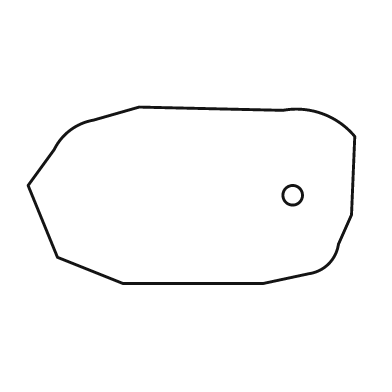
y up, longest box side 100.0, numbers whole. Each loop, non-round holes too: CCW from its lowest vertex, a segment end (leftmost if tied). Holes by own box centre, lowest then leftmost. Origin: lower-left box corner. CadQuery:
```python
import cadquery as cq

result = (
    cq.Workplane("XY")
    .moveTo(29.0, 0.0)
    .lineTo(72.0, 0.0)
    .lineTo(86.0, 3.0)
    .threePointArc((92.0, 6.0), (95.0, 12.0))
    .lineTo(99.0, 21.0)
    .lineTo(100.0, 45.0)
    .threePointArc((90.0, 52.0), (78.0, 53.0))
    .lineTo(34.0, 54.0)
    .lineTo(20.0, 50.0)
    .threePointArc((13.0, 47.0), (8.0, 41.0))
    .lineTo(0.0, 30.0)
    .lineTo(9.0, 8.0)
    .close()
    .moveTo(81.0, 27.0)
    .circle(3.0)
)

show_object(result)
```